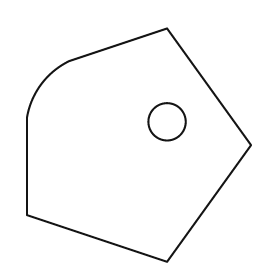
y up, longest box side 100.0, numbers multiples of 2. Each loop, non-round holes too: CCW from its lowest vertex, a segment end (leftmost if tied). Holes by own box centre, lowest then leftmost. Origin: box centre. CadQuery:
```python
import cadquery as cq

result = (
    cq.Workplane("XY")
    .moveTo(12.0, -50.0)
    .lineTo(48.0, 0.0)
    .lineTo(12.0, 50.0)
    .lineTo(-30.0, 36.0)
    .threePointArc((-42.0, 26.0), (-48.0, 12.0))
    .lineTo(-48.0, -30.0)
    .close()
    .moveTo(12.0, 10.0)
    .circle(8.0)
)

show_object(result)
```